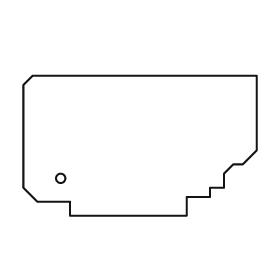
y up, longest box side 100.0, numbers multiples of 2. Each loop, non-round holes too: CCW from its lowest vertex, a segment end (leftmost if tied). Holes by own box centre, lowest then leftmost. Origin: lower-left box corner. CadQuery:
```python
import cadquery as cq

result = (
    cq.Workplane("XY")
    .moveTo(20.0, 0.0)
    .lineTo(70.0, 0.0)
    .lineTo(70.0, 8.0)
    .lineTo(80.0, 8.0)
    .lineTo(80.0, 12.0)
    .lineTo(86.0, 12.0)
    .lineTo(86.0, 18.0)
    .lineTo(90.0, 22.0)
    .lineTo(94.0, 22.0)
    .lineTo(100.0, 28.0)
    .lineTo(100.0, 60.0)
    .lineTo(4.0, 60.0)
    .lineTo(0.0, 56.0)
    .lineTo(0.0, 12.0)
    .lineTo(6.0, 6.0)
    .lineTo(20.0, 6.0)
    .close()
    .moveTo(16.0, 16.0)
    .circle(2.0)
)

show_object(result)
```